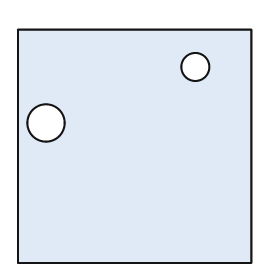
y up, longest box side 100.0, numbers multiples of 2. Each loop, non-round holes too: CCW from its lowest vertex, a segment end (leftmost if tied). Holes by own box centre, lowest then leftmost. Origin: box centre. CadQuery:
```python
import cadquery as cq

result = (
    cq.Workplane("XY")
    .moveTo(-50.0, -50.0)
    .lineTo(50.0, -50.0)
    .lineTo(50.0, 50.0)
    .lineTo(-50.0, 50.0)
    .close()
    .moveTo(-38.0, 10.0)
    .circle(8.0)
    .moveTo(26.0, 34.0)
    .circle(6.0)
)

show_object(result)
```